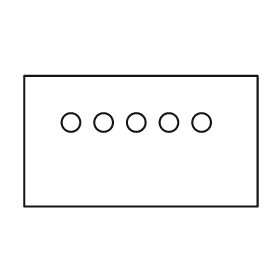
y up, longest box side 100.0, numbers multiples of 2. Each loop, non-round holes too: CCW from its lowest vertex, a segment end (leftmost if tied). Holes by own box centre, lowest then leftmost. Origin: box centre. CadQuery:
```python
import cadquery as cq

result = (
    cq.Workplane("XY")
    .moveTo(-50.0, -28.0)
    .lineTo(50.0, -28.0)
    .lineTo(50.0, 28.0)
    .lineTo(-50.0, 28.0)
    .close()
    .moveTo(-30.0, 8.0)
    .circle(4.0)
    .moveTo(-16.0, 8.0)
    .circle(4.0)
    .moveTo(-2.0, 8.0)
    .circle(4.0)
    .moveTo(12.0, 8.0)
    .circle(4.0)
    .moveTo(26.0, 8.0)
    .circle(4.0)
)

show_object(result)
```